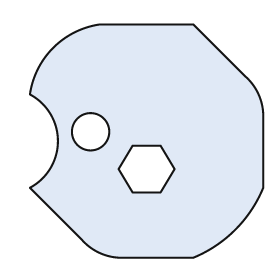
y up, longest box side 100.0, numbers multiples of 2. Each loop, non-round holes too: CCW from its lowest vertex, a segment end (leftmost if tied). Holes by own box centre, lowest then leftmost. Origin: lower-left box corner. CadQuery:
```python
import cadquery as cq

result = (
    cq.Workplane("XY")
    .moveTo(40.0, 0.0)
    .lineTo(70.0, 0.0)
    .threePointArc((88.0, 12.0), (100.0, 30.0))
    .lineTo(100.0, 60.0)
    .threePointArc((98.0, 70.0), (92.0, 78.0))
    .lineTo(70.0, 100.0)
    .lineTo(30.0, 100.0)
    .threePointArc((10.0, 90.0), (0.0, 70.0))
    .threePointArc((12.0, 50.0), (0.0, 30.0))
    .lineTo(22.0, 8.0)
    .threePointArc((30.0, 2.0), (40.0, 0.0))
    .close()
    .moveTo(44.0, 28.0)
    .lineTo(56.0, 28.0)
    .lineTo(62.0, 38.0)
    .lineTo(56.0, 48.0)
    .lineTo(44.0, 48.0)
    .lineTo(38.0, 38.0)
    .close()
    .moveTo(26.0, 54.0)
    .circle(8.0)
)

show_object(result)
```